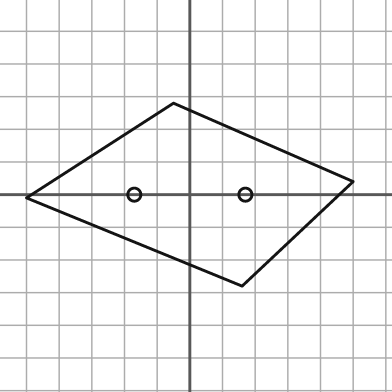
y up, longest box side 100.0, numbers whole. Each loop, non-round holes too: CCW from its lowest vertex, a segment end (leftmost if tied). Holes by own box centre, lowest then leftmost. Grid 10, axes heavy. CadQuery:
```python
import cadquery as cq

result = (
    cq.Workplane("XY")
    .moveTo(16.0, -28.0)
    .lineTo(50.0, 4.0)
    .lineTo(-5.0, 28.0)
    .lineTo(-50.0, -1.0)
    .close()
    .moveTo(-17.0, 0.0)
    .circle(2.0)
    .moveTo(17.0, 0.0)
    .circle(2.0)
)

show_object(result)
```